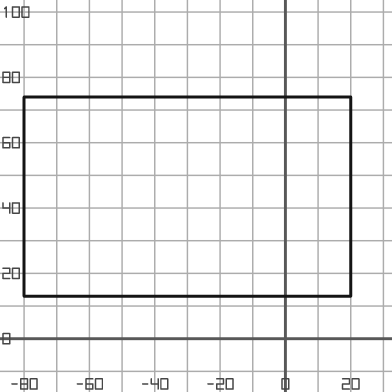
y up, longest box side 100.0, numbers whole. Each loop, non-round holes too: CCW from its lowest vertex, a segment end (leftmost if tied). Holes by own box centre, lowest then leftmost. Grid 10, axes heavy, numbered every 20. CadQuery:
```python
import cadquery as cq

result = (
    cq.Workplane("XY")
    .moveTo(-80.0, 13.0)
    .lineTo(20.0, 13.0)
    .lineTo(20.0, 74.0)
    .lineTo(-80.0, 74.0)
    .close()
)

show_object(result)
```